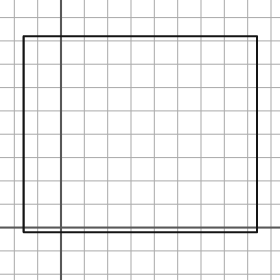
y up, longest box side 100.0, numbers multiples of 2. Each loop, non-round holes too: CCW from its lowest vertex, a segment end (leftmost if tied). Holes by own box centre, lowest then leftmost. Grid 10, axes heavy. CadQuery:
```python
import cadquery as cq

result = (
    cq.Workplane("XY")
    .moveTo(-16.0, -2.0)
    .lineTo(84.0, -2.0)
    .lineTo(84.0, 82.0)
    .lineTo(-16.0, 82.0)
    .close()
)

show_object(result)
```